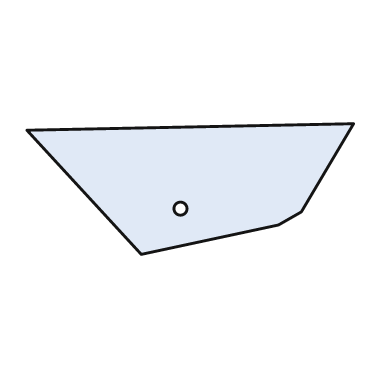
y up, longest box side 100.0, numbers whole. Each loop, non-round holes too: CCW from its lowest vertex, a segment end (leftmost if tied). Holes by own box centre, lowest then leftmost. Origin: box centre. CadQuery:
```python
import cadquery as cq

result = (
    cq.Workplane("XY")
    .moveTo(-15.0, -20.0)
    .lineTo(27.0, -11.0)
    .lineTo(34.0, -7.0)
    .lineTo(50.0, 20.0)
    .lineTo(-50.0, 18.0)
    .close()
    .moveTo(-3.0, -6.0)
    .circle(2.0)
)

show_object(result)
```